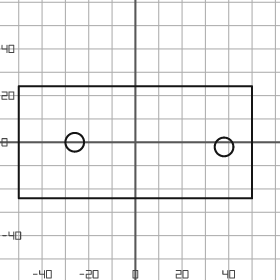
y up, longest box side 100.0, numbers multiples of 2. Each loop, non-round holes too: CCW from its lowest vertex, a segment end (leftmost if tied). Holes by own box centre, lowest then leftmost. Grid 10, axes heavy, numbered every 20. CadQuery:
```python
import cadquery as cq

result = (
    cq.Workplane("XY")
    .moveTo(-50.0, -24.0)
    .lineTo(50.0, -24.0)
    .lineTo(50.0, 24.0)
    .lineTo(-50.0, 24.0)
    .close()
    .moveTo(38.0, -2.0)
    .circle(4.0)
    .moveTo(-26.0, 0.0)
    .circle(4.0)
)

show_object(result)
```